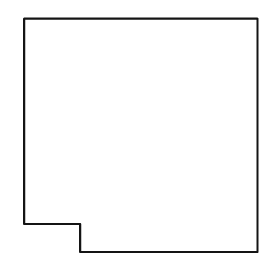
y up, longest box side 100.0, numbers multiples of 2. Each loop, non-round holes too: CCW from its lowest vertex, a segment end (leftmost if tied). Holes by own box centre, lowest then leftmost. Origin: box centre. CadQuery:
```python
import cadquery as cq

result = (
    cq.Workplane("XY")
    .moveTo(-26.0, -50.0)
    .lineTo(50.0, -50.0)
    .lineTo(50.0, 50.0)
    .lineTo(-50.0, 50.0)
    .lineTo(-50.0, -38.0)
    .lineTo(-26.0, -38.0)
    .close()
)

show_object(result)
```